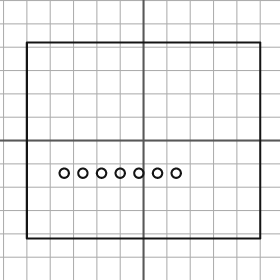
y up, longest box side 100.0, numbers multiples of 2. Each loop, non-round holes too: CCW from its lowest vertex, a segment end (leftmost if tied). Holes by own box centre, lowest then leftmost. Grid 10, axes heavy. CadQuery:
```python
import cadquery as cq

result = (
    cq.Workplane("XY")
    .moveTo(-50.0, -42.0)
    .lineTo(50.0, -42.0)
    .lineTo(50.0, 42.0)
    .lineTo(-50.0, 42.0)
    .close()
    .moveTo(-34.0, -14.0)
    .circle(2.0)
    .moveTo(-26.0, -14.0)
    .circle(2.0)
    .moveTo(-18.0, -14.0)
    .circle(2.0)
    .moveTo(-10.0, -14.0)
    .circle(2.0)
    .moveTo(-2.0, -14.0)
    .circle(2.0)
    .moveTo(6.0, -14.0)
    .circle(2.0)
    .moveTo(14.0, -14.0)
    .circle(2.0)
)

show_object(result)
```